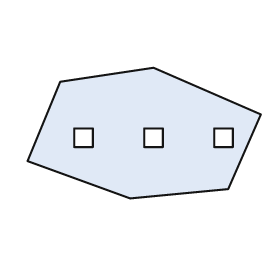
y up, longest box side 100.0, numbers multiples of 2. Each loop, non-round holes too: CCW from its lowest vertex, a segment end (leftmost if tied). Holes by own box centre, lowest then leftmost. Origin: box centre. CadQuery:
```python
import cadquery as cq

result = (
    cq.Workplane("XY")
    .moveTo(-6.0, -28.0)
    .lineTo(36.0, -24.0)
    .lineTo(50.0, 8.0)
    .lineTo(4.0, 28.0)
    .lineTo(-36.0, 22.0)
    .lineTo(-50.0, -12.0)
    .close()
    .moveTo(-30.0, -6.0)
    .lineTo(-22.0, -6.0)
    .lineTo(-22.0, 2.0)
    .lineTo(-30.0, 2.0)
    .close()
    .moveTo(0.0, -6.0)
    .lineTo(8.0, -6.0)
    .lineTo(8.0, 2.0)
    .lineTo(0.0, 2.0)
    .close()
    .moveTo(30.0, -6.0)
    .lineTo(38.0, -6.0)
    .lineTo(38.0, 2.0)
    .lineTo(30.0, 2.0)
    .close()
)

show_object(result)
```